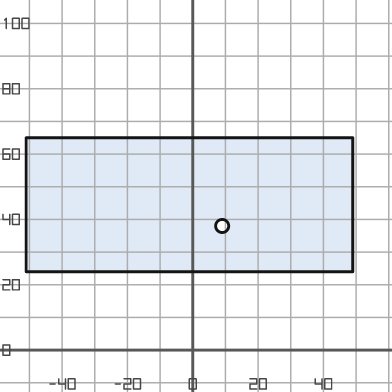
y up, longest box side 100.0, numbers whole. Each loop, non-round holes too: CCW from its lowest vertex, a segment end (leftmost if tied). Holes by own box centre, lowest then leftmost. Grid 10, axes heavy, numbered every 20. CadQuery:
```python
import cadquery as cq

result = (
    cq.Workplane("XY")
    .moveTo(-51.0, 24.0)
    .lineTo(49.0, 24.0)
    .lineTo(49.0, 65.0)
    .lineTo(-51.0, 65.0)
    .close()
    .moveTo(9.0, 38.0)
    .circle(2.0)
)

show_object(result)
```